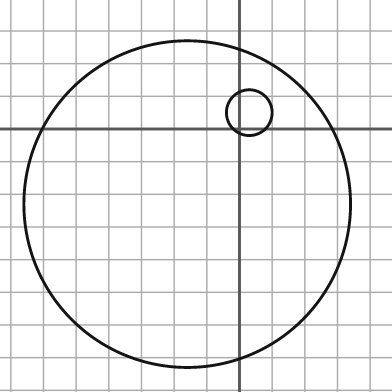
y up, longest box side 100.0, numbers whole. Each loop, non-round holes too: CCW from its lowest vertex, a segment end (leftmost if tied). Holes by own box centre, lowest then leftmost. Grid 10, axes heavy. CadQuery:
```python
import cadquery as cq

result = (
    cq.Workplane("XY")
    .moveTo(-16.0, -23.0)
    .circle(50.0)
    .moveTo(3.0, 5.0)
    .circle(7.0)
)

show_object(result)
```